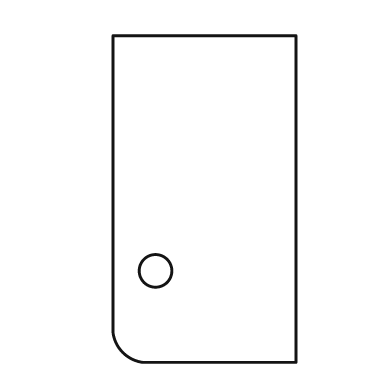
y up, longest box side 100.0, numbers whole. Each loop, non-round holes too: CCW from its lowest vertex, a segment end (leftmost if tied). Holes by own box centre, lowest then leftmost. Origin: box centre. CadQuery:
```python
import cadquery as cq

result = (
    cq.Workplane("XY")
    .moveTo(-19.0, -50.0)
    .lineTo(28.0, -50.0)
    .lineTo(28.0, 50.0)
    .lineTo(-28.0, 50.0)
    .lineTo(-28.0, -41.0)
    .threePointArc((-25.0, -47.0), (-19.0, -50.0))
    .close()
    .moveTo(-15.0, -22.0)
    .circle(5.0)
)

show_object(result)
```